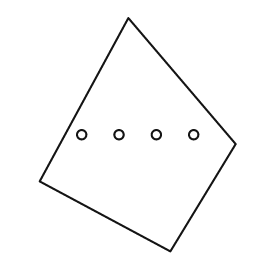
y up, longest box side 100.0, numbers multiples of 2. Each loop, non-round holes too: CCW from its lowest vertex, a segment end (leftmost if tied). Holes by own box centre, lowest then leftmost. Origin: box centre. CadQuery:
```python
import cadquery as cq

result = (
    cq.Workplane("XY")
    .moveTo(14.0, -50.0)
    .lineTo(42.0, -4.0)
    .lineTo(-4.0, 50.0)
    .lineTo(-42.0, -20.0)
    .close()
    .moveTo(-24.0, 0.0)
    .circle(2.0)
    .moveTo(-8.0, 0.0)
    .circle(2.0)
    .moveTo(8.0, 0.0)
    .circle(2.0)
    .moveTo(24.0, 0.0)
    .circle(2.0)
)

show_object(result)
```